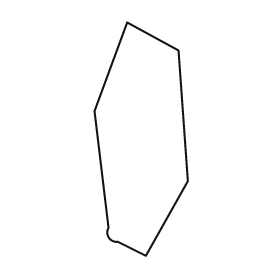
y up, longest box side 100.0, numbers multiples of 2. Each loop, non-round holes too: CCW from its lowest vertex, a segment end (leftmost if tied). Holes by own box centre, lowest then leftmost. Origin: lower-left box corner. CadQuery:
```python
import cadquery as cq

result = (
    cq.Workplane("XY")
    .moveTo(22.0, 0.0)
    .lineTo(40.0, 32.0)
    .lineTo(36.0, 88.0)
    .lineTo(14.0, 100.0)
    .lineTo(0.0, 62.0)
    .lineTo(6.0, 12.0)
    .threePointArc((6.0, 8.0), (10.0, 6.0))
    .close()
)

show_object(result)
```